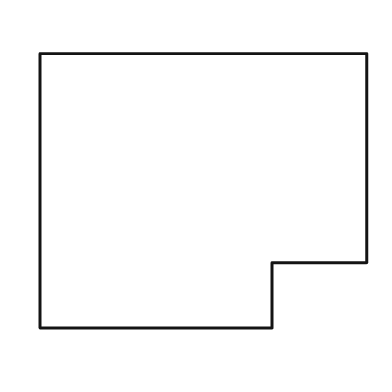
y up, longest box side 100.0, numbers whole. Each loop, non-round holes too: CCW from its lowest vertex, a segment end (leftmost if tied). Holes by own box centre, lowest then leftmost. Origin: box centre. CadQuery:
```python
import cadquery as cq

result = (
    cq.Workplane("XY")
    .moveTo(-50.0, -42.0)
    .lineTo(21.0, -42.0)
    .lineTo(21.0, -22.0)
    .lineTo(50.0, -22.0)
    .lineTo(50.0, 42.0)
    .lineTo(-50.0, 42.0)
    .close()
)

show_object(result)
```